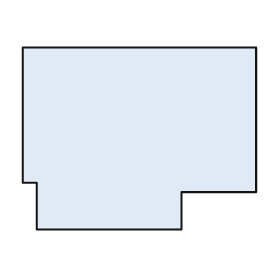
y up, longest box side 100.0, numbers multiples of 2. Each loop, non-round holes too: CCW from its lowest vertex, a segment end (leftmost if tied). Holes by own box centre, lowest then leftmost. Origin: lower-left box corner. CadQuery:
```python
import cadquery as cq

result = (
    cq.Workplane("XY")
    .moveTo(6.0, 0.0)
    .lineTo(68.0, 0.0)
    .lineTo(68.0, 16.0)
    .lineTo(100.0, 16.0)
    .lineTo(100.0, 78.0)
    .lineTo(0.0, 78.0)
    .lineTo(0.0, 20.0)
    .lineTo(6.0, 20.0)
    .close()
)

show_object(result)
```